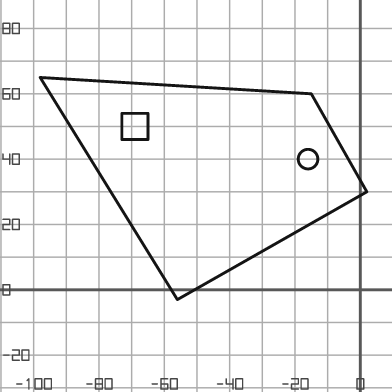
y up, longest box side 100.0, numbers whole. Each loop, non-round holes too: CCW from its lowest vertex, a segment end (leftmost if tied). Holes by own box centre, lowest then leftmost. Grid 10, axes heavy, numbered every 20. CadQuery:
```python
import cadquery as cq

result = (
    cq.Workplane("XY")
    .moveTo(-56.0, -3.0)
    .lineTo(2.0, 30.0)
    .lineTo(-15.0, 60.0)
    .lineTo(-98.0, 65.0)
    .close()
    .moveTo(-16.0, 40.0)
    .circle(3.0)
    .moveTo(-73.0, 46.0)
    .lineTo(-65.0, 46.0)
    .lineTo(-65.0, 54.0)
    .lineTo(-73.0, 54.0)
    .close()
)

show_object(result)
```